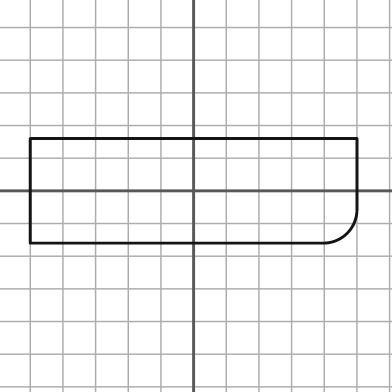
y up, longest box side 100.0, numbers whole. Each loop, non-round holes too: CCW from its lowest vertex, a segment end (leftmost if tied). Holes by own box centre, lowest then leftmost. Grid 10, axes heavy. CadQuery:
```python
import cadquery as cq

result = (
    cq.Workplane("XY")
    .moveTo(-50.0, -16.0)
    .lineTo(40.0, -16.0)
    .threePointArc((47.0, -13.0), (50.0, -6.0))
    .lineTo(50.0, 16.0)
    .lineTo(-50.0, 16.0)
    .close()
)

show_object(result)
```